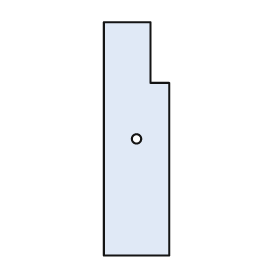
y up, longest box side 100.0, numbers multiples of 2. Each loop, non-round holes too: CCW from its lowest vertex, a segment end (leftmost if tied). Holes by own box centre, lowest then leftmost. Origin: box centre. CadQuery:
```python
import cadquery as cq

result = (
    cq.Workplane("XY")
    .moveTo(-14.0, -50.0)
    .lineTo(14.0, -50.0)
    .lineTo(14.0, 24.0)
    .lineTo(6.0, 24.0)
    .lineTo(6.0, 50.0)
    .lineTo(-14.0, 50.0)
    .close()
    .moveTo(0.0, 0.0)
    .circle(2.0)
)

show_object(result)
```